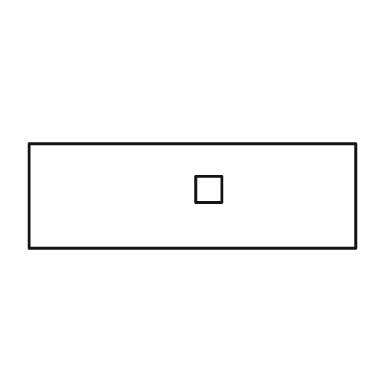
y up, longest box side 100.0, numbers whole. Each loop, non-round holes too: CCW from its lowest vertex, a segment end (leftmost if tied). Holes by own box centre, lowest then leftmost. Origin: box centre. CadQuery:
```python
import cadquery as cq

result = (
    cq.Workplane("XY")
    .moveTo(-50.0, -16.0)
    .lineTo(50.0, -16.0)
    .lineTo(50.0, 16.0)
    .lineTo(-50.0, 16.0)
    .close()
    .moveTo(1.0, -2.0)
    .lineTo(9.0, -2.0)
    .lineTo(9.0, 6.0)
    .lineTo(1.0, 6.0)
    .close()
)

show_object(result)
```